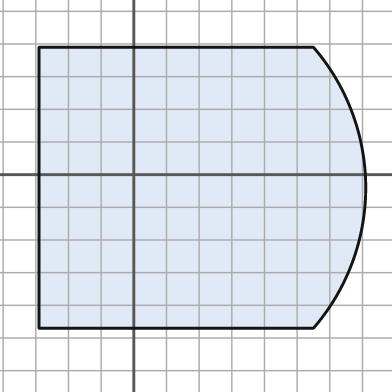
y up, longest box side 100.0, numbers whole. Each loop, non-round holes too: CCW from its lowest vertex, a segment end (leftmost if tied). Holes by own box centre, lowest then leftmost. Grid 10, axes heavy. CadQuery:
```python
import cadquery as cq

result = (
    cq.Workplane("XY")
    .moveTo(-29.0, -47.0)
    .lineTo(55.0, -47.0)
    .threePointArc((71.0, -4.0), (55.0, 39.0))
    .lineTo(-29.0, 39.0)
    .close()
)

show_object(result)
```